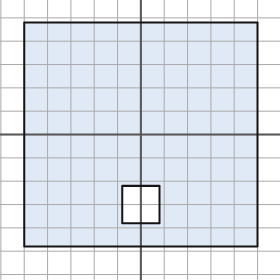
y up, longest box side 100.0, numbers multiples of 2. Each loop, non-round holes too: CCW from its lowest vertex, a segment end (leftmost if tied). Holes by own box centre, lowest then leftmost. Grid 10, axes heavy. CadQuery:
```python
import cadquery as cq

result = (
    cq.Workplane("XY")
    .moveTo(-50.0, -48.0)
    .lineTo(50.0, -48.0)
    .lineTo(50.0, 48.0)
    .lineTo(-50.0, 48.0)
    .close()
    .moveTo(-8.0, -38.0)
    .lineTo(8.0, -38.0)
    .lineTo(8.0, -22.0)
    .lineTo(-8.0, -22.0)
    .close()
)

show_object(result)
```